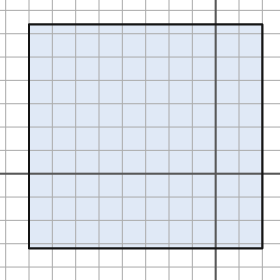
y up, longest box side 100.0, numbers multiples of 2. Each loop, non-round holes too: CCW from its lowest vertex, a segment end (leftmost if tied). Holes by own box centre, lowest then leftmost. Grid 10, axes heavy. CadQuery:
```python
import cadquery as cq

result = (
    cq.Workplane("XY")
    .moveTo(-80.0, -32.0)
    .lineTo(20.0, -32.0)
    .lineTo(20.0, 64.0)
    .lineTo(-80.0, 64.0)
    .close()
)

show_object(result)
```